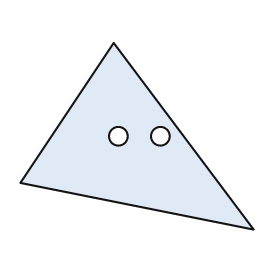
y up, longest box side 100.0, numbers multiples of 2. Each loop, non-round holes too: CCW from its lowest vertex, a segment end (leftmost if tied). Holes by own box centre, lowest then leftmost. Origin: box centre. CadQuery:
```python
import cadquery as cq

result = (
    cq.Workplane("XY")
    .moveTo(50.0, -40.0)
    .lineTo(-10.0, 40.0)
    .lineTo(-50.0, -20.0)
    .close()
    .moveTo(-8.0, 0.0)
    .circle(4.0)
    .moveTo(10.0, 0.0)
    .circle(4.0)
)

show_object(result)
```